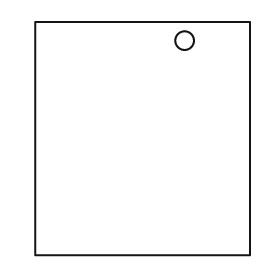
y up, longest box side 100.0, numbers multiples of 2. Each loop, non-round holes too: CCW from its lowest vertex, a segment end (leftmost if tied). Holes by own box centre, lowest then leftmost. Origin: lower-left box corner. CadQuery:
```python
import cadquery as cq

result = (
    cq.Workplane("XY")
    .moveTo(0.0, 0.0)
    .lineTo(92.0, 0.0)
    .lineTo(92.0, 100.0)
    .lineTo(0.0, 100.0)
    .close()
    .moveTo(64.0, 92.0)
    .circle(4.0)
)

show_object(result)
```